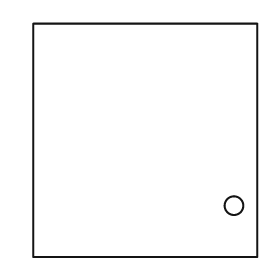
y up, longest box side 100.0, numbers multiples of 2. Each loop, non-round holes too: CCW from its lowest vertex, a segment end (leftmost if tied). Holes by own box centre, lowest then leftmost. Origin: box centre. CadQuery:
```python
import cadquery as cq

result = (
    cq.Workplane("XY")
    .moveTo(-48.0, -50.0)
    .lineTo(48.0, -50.0)
    .lineTo(48.0, 50.0)
    .lineTo(-48.0, 50.0)
    .close()
    .moveTo(38.0, -28.0)
    .circle(4.0)
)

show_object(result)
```